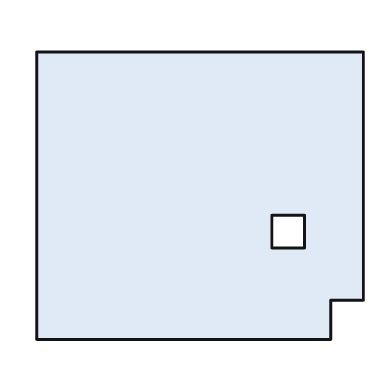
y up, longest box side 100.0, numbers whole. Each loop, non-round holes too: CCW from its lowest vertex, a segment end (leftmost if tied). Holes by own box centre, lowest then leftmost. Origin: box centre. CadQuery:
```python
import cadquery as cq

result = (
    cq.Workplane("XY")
    .moveTo(-50.0, -44.0)
    .lineTo(40.0, -44.0)
    .lineTo(40.0, -32.0)
    .lineTo(50.0, -32.0)
    .lineTo(50.0, 44.0)
    .lineTo(-50.0, 44.0)
    .close()
    .moveTo(22.0, -16.0)
    .lineTo(32.0, -16.0)
    .lineTo(32.0, -6.0)
    .lineTo(22.0, -6.0)
    .close()
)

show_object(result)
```